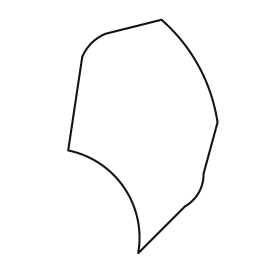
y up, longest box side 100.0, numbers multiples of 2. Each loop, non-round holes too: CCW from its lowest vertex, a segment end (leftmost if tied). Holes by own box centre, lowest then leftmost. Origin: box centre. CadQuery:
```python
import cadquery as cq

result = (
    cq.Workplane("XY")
    .moveTo(-2.0, -50.0)
    .lineTo(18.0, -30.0)
    .threePointArc((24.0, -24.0), (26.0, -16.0))
    .lineTo(32.0, 6.0)
    .threePointArc((24.0, 30.0), (8.0, 50.0))
    .lineTo(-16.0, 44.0)
    .threePointArc((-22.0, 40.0), (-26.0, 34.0))
    .lineTo(-32.0, -6.0)
    .threePointArc((-8.0, -22.0), (-2.0, -50.0))
    .close()
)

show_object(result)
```